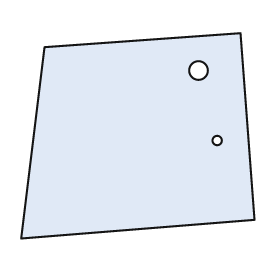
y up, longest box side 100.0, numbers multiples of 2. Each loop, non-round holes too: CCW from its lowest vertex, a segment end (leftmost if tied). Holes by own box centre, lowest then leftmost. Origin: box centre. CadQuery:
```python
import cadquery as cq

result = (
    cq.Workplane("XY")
    .moveTo(-50.0, -44.0)
    .lineTo(50.0, -36.0)
    .lineTo(44.0, 44.0)
    .lineTo(-40.0, 38.0)
    .close()
    .moveTo(34.0, -2.0)
    .circle(2.0)
    .moveTo(26.0, 28.0)
    .circle(4.0)
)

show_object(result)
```